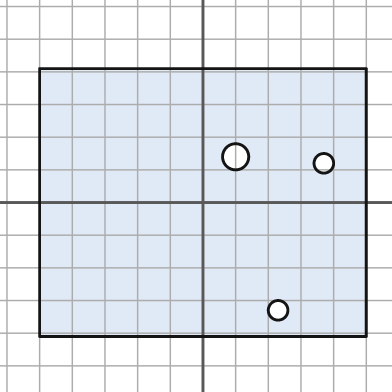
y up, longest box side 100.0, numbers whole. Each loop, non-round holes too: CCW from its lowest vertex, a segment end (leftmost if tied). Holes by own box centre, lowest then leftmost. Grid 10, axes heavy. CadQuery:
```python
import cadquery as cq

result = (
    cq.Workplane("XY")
    .moveTo(-50.0, -41.0)
    .lineTo(50.0, -41.0)
    .lineTo(50.0, 41.0)
    .lineTo(-50.0, 41.0)
    .close()
    .moveTo(23.0, -33.0)
    .circle(3.0)
    .moveTo(37.0, 12.0)
    .circle(3.0)
    .moveTo(10.0, 14.0)
    .circle(4.0)
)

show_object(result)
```